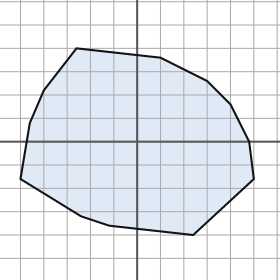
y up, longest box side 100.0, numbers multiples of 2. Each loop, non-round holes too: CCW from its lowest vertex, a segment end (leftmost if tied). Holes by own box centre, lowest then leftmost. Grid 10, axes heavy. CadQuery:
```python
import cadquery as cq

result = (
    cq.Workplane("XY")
    .moveTo(24.0, -40.0)
    .lineTo(50.0, -16.0)
    .lineTo(48.0, 0.0)
    .lineTo(40.0, 16.0)
    .lineTo(30.0, 26.0)
    .lineTo(10.0, 36.0)
    .lineTo(-26.0, 40.0)
    .lineTo(-40.0, 22.0)
    .lineTo(-46.0, 8.0)
    .lineTo(-50.0, -16.0)
    .lineTo(-24.0, -32.0)
    .lineTo(-12.0, -36.0)
    .close()
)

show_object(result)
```